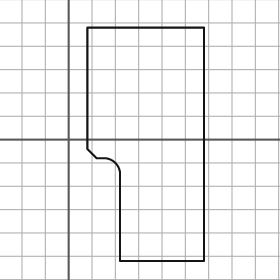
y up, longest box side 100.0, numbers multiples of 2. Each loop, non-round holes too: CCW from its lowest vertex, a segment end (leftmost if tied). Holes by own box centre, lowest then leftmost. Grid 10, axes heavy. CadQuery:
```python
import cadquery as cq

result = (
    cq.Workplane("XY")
    .moveTo(22.0, -52.0)
    .lineTo(58.0, -52.0)
    .lineTo(58.0, 48.0)
    .lineTo(8.0, 48.0)
    .lineTo(8.0, -4.0)
    .lineTo(12.0, -8.0)
    .lineTo(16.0, -8.0)
    .threePointArc((20.0, -10.0), (22.0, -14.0))
    .close()
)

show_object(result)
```